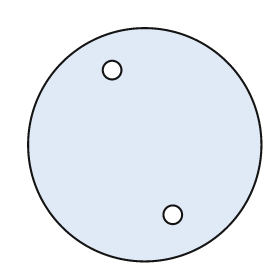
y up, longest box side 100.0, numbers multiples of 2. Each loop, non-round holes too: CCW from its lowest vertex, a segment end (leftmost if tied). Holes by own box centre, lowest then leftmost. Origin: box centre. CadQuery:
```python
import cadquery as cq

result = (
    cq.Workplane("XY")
    .moveTo(0.0, 0.0)
    .circle(50.0)
    .moveTo(12.0, -30.0)
    .circle(4.0)
    .moveTo(-14.0, 32.0)
    .circle(4.0)
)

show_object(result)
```